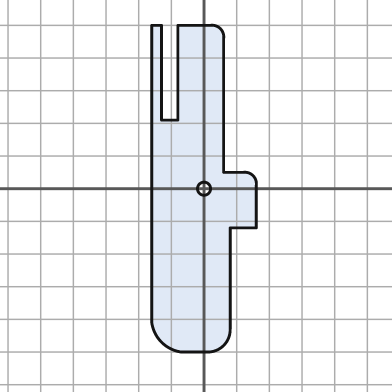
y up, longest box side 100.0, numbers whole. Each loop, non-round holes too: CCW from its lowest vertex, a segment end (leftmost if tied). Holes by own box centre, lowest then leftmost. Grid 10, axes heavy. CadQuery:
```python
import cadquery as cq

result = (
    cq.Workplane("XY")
    .moveTo(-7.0, -50.0)
    .lineTo(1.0, -50.0)
    .threePointArc((6.0, -48.0), (8.0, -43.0))
    .lineTo(8.0, -12.0)
    .lineTo(16.0, -12.0)
    .lineTo(16.0, 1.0)
    .threePointArc((15.0, 4.0), (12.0, 5.0))
    .lineTo(6.0, 5.0)
    .lineTo(6.0, 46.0)
    .threePointArc((5.0, 49.0), (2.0, 50.0))
    .lineTo(-8.0, 50.0)
    .lineTo(-8.0, 21.0)
    .lineTo(-13.0, 21.0)
    .lineTo(-13.0, 50.0)
    .lineTo(-16.0, 50.0)
    .lineTo(-16.0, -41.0)
    .threePointArc((-13.0, -47.0), (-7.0, -50.0))
    .close()
    .moveTo(0.0, 0.0)
    .circle(2.0)
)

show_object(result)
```